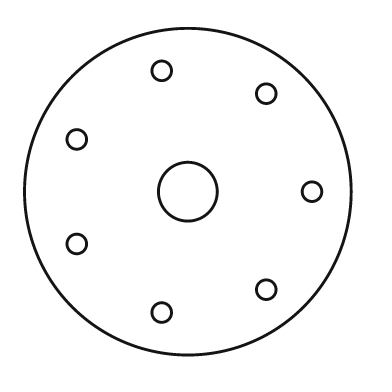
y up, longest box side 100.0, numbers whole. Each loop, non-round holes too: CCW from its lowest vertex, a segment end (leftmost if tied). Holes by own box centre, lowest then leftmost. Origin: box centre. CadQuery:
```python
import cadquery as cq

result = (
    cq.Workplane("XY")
    .moveTo(0.0, 0.0)
    .circle(50.0)
    .moveTo(-8.0, -37.0)
    .circle(3.0)
    .moveTo(24.0, -30.0)
    .circle(3.0)
    .moveTo(-34.0, -16.0)
    .circle(3.0)
    .moveTo(0.0, 0.0)
    .circle(9.0)
    .moveTo(38.0, 0.0)
    .circle(3.0)
    .moveTo(-34.0, 16.0)
    .circle(3.0)
    .moveTo(24.0, 30.0)
    .circle(3.0)
    .moveTo(-8.0, 37.0)
    .circle(3.0)
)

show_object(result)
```